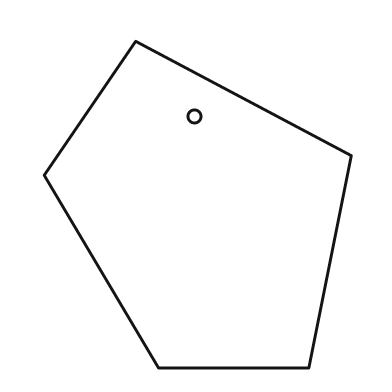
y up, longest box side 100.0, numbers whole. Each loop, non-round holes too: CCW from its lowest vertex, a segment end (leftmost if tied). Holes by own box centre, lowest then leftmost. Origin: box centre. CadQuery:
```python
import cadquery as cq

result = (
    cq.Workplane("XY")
    .moveTo(-12.0, -50.0)
    .lineTo(34.0, -50.0)
    .lineTo(47.0, 15.0)
    .lineTo(-19.0, 50.0)
    .lineTo(-47.0, 9.0)
    .close()
    .moveTo(-1.0, 27.0)
    .circle(2.0)
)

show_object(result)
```